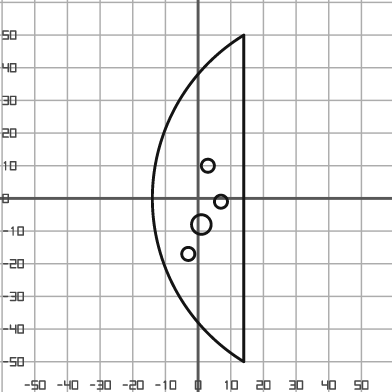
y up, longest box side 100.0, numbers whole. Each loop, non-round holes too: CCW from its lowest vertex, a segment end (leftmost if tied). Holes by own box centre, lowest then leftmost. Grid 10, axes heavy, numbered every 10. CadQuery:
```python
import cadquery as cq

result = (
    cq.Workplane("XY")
    .moveTo(14.0, -50.0)
    .lineTo(14.0, 50.0)
    .threePointArc((-14.0, 0.0), (14.0, -50.0))
    .close()
    .moveTo(-3.0, -17.0)
    .circle(2.0)
    .moveTo(1.0, -8.0)
    .circle(3.0)
    .moveTo(7.0, -1.0)
    .circle(2.0)
    .moveTo(3.0, 10.0)
    .circle(2.0)
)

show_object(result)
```